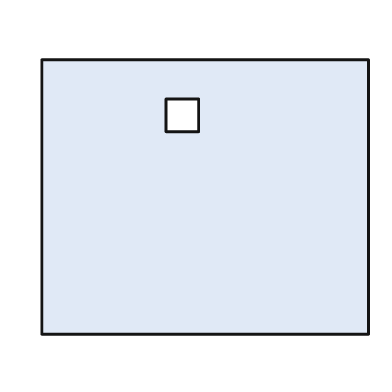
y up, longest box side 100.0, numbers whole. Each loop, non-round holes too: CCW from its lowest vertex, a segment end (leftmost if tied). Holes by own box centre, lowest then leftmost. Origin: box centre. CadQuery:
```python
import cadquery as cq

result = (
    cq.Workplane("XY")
    .moveTo(-50.0, -42.0)
    .lineTo(50.0, -42.0)
    .lineTo(50.0, 42.0)
    .lineTo(-50.0, 42.0)
    .close()
    .moveTo(-12.0, 20.0)
    .lineTo(-2.0, 20.0)
    .lineTo(-2.0, 30.0)
    .lineTo(-12.0, 30.0)
    .close()
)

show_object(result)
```